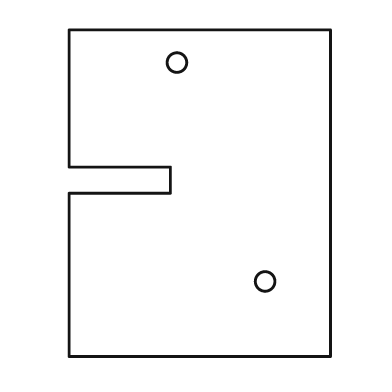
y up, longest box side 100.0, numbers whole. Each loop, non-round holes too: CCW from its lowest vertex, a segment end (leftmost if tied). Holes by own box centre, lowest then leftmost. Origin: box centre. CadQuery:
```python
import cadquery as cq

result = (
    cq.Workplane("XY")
    .moveTo(-40.0, -50.0)
    .lineTo(40.0, -50.0)
    .lineTo(40.0, 50.0)
    .lineTo(-40.0, 50.0)
    .lineTo(-40.0, 8.0)
    .lineTo(-9.0, 8.0)
    .lineTo(-9.0, 0.0)
    .lineTo(-40.0, 0.0)
    .close()
    .moveTo(20.0, -27.0)
    .circle(3.0)
    .moveTo(-7.0, 40.0)
    .circle(3.0)
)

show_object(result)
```